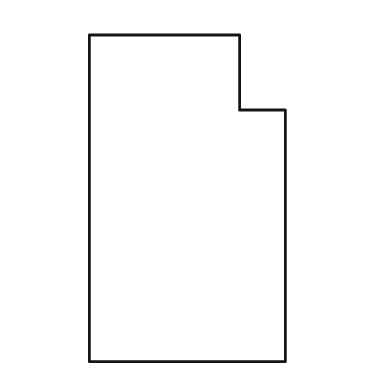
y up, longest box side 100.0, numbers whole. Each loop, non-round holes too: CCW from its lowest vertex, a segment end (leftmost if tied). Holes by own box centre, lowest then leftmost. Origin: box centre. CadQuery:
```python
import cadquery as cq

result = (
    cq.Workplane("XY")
    .moveTo(-30.0, -50.0)
    .lineTo(30.0, -50.0)
    .lineTo(30.0, 27.0)
    .lineTo(16.0, 27.0)
    .lineTo(16.0, 50.0)
    .lineTo(-30.0, 50.0)
    .close()
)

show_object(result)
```